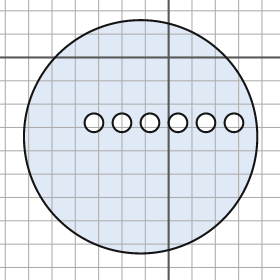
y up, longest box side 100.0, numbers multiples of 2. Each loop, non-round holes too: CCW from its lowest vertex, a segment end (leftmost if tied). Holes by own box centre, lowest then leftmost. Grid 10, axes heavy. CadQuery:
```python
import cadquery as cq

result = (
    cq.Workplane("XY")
    .moveTo(-12.0, -34.0)
    .circle(50.0)
    .moveTo(-32.0, -28.0)
    .circle(4.0)
    .moveTo(-20.0, -28.0)
    .circle(4.0)
    .moveTo(-8.0, -28.0)
    .circle(4.0)
    .moveTo(4.0, -28.0)
    .circle(4.0)
    .moveTo(16.0, -28.0)
    .circle(4.0)
    .moveTo(28.0, -28.0)
    .circle(4.0)
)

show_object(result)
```